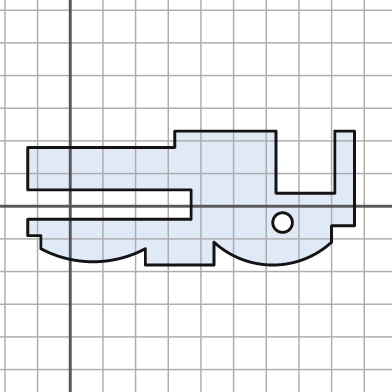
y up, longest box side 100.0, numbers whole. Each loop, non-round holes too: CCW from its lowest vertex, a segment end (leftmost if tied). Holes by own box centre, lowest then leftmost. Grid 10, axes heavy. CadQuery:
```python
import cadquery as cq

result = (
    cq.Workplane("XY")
    .moveTo(23.0, -18.0)
    .lineTo(44.0, -18.0)
    .lineTo(44.0, -11.0)
    .threePointArc((62.0, -18.0), (80.0, -11.0))
    .lineTo(80.0, -6.0)
    .lineTo(87.0, -6.0)
    .lineTo(87.0, 23.0)
    .lineTo(81.0, 23.0)
    .lineTo(81.0, 4.0)
    .lineTo(63.0, 4.0)
    .lineTo(63.0, 23.0)
    .lineTo(32.0, 23.0)
    .lineTo(32.0, 18.0)
    .lineTo(-13.0, 18.0)
    .lineTo(-13.0, 5.0)
    .lineTo(37.0, 5.0)
    .lineTo(37.0, -4.0)
    .lineTo(-13.0, -4.0)
    .lineTo(-13.0, -9.0)
    .lineTo(-9.0, -9.0)
    .lineTo(-9.0, -13.0)
    .threePointArc((7.0, -17.0), (23.0, -13.0))
    .close()
    .moveTo(65.0, -5.0)
    .circle(3.0)
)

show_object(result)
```